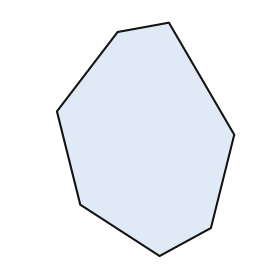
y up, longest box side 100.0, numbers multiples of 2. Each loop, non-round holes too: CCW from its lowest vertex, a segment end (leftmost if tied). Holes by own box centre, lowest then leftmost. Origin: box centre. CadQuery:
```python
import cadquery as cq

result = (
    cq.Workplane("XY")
    .moveTo(6.0, -50.0)
    .lineTo(28.0, -38.0)
    .lineTo(38.0, 2.0)
    .lineTo(10.0, 50.0)
    .lineTo(-12.0, 46.0)
    .lineTo(-38.0, 12.0)
    .lineTo(-28.0, -28.0)
    .close()
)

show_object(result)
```